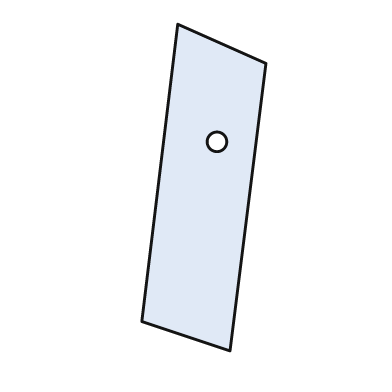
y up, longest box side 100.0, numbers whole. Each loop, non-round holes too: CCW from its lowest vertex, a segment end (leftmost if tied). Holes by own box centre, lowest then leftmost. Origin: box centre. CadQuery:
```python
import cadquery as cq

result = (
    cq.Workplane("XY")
    .moveTo(8.0, -50.0)
    .lineTo(19.0, 38.0)
    .lineTo(-8.0, 50.0)
    .lineTo(-19.0, -41.0)
    .close()
    .moveTo(4.0, 14.0)
    .circle(3.0)
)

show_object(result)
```